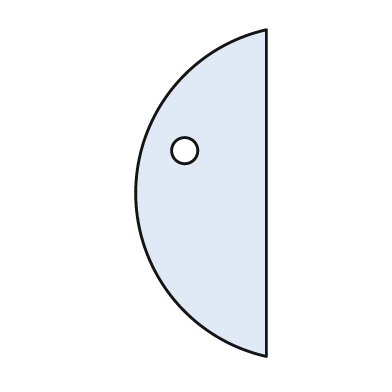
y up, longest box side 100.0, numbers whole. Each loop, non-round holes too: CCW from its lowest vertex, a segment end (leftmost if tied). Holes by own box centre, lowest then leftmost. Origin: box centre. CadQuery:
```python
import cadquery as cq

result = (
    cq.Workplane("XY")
    .moveTo(20.0, -50.0)
    .lineTo(20.0, 50.0)
    .threePointArc((-20.0, 0.0), (20.0, -50.0))
    .close()
    .moveTo(-5.0, 13.0)
    .circle(4.0)
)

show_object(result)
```